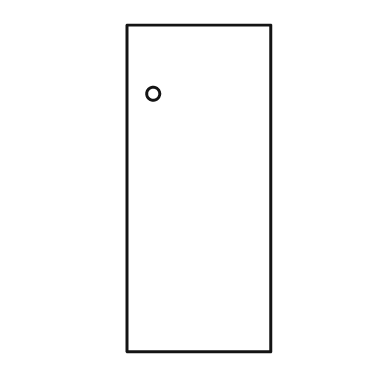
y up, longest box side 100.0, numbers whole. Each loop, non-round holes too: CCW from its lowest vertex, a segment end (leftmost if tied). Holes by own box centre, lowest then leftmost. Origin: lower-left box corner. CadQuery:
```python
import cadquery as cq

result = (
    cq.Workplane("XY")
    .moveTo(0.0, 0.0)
    .lineTo(44.0, 0.0)
    .lineTo(44.0, 100.0)
    .lineTo(0.0, 100.0)
    .close()
    .moveTo(8.0, 79.0)
    .circle(2.0)
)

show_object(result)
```